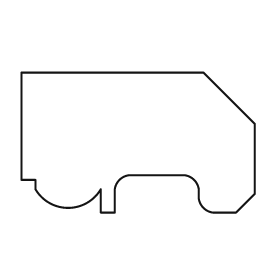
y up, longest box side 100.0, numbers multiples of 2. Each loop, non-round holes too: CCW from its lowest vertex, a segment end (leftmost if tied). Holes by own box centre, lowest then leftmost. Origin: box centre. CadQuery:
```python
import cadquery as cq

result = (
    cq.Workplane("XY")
    .moveTo(-16.0, -30.0)
    .lineTo(-10.0, -30.0)
    .lineTo(-10.0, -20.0)
    .threePointArc((-8.0, -16.0), (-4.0, -14.0))
    .lineTo(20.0, -14.0)
    .threePointArc((24.0, -16.0), (26.0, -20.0))
    .lineTo(26.0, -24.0)
    .threePointArc((28.0, -28.0), (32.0, -30.0))
    .lineTo(42.0, -30.0)
    .lineTo(50.0, -22.0)
    .lineTo(50.0, 8.0)
    .lineTo(28.0, 30.0)
    .lineTo(-50.0, 30.0)
    .lineTo(-50.0, -16.0)
    .lineTo(-44.0, -16.0)
    .lineTo(-44.0, -20.0)
    .threePointArc((-30.0, -28.0), (-16.0, -20.0))
    .close()
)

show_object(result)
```